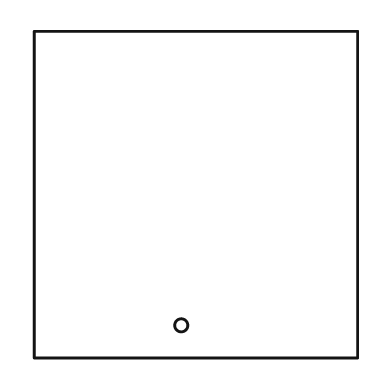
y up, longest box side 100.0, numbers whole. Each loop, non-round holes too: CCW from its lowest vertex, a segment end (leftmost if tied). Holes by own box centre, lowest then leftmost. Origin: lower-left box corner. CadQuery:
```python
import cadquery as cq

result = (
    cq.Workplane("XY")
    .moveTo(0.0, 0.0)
    .lineTo(99.0, 0.0)
    .lineTo(99.0, 100.0)
    .lineTo(0.0, 100.0)
    .close()
    .moveTo(45.0, 10.0)
    .circle(2.0)
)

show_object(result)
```